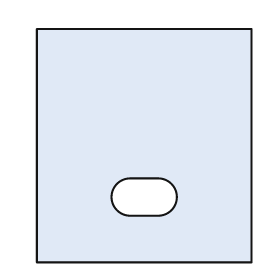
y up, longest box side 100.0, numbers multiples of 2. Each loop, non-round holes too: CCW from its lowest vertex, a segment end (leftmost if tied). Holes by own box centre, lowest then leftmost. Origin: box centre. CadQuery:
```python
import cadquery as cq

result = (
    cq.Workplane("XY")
    .moveTo(-46.0, -50.0)
    .lineTo(46.0, -50.0)
    .lineTo(46.0, 50.0)
    .lineTo(-46.0, 50.0)
    .close()
    .moveTo(-6.0, -30.0)
    .lineTo(6.0, -30.0)
    .threePointArc((14.0, -22.0), (6.0, -14.0))
    .lineTo(-6.0, -14.0)
    .threePointArc((-14.0, -22.0), (-6.0, -30.0))
    .close()
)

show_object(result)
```